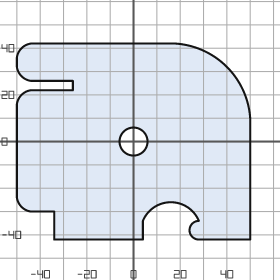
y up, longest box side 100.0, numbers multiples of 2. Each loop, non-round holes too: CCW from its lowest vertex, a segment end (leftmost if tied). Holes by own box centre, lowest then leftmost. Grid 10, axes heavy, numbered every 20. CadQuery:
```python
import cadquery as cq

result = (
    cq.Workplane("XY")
    .moveTo(-34.0, -42.0)
    .lineTo(4.0, -42.0)
    .lineTo(4.0, -34.0)
    .threePointArc((16.0, -26.0), (28.0, -34.0))
    .threePointArc((24.0, -38.0), (28.0, -42.0))
    .lineTo(50.0, -42.0)
    .lineTo(50.0, 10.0)
    .threePointArc((40.0, 32.0), (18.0, 42.0))
    .lineTo(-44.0, 42.0)
    .threePointArc((-48.0, 40.0), (-50.0, 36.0))
    .lineTo(-50.0, 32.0)
    .threePointArc((-48.0, 28.0), (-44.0, 26.0))
    .lineTo(-26.0, 26.0)
    .lineTo(-26.0, 22.0)
    .lineTo(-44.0, 22.0)
    .threePointArc((-48.0, 20.0), (-50.0, 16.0))
    .lineTo(-50.0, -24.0)
    .threePointArc((-48.0, -28.0), (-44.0, -30.0))
    .lineTo(-34.0, -30.0)
    .close()
    .moveTo(0.0, 0.0)
    .circle(6.0)
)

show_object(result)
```